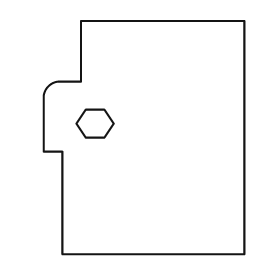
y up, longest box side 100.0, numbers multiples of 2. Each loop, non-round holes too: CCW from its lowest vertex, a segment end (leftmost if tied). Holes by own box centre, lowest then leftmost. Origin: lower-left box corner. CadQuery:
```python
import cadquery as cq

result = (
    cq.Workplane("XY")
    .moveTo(8.0, 0.0)
    .lineTo(86.0, 0.0)
    .lineTo(86.0, 100.0)
    .lineTo(16.0, 100.0)
    .lineTo(16.0, 74.0)
    .lineTo(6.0, 74.0)
    .threePointArc((2.0, 72.0), (0.0, 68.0))
    .lineTo(0.0, 44.0)
    .lineTo(8.0, 44.0)
    .close()
    .moveTo(18.0, 50.0)
    .lineTo(26.0, 50.0)
    .lineTo(30.0, 56.0)
    .lineTo(26.0, 62.0)
    .lineTo(18.0, 62.0)
    .lineTo(14.0, 56.0)
    .close()
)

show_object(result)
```